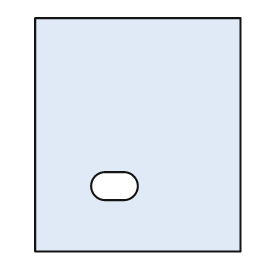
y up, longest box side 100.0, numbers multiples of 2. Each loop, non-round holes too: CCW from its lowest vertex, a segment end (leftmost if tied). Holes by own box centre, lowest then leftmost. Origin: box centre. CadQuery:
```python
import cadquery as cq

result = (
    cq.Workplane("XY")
    .moveTo(-44.0, -50.0)
    .lineTo(44.0, -50.0)
    .lineTo(44.0, 50.0)
    .lineTo(-44.0, 50.0)
    .close()
    .moveTo(-14.0, -28.0)
    .lineTo(-6.0, -28.0)
    .threePointArc((0.0, -22.0), (-6.0, -16.0))
    .lineTo(-14.0, -16.0)
    .threePointArc((-20.0, -22.0), (-14.0, -28.0))
    .close()
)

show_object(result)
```